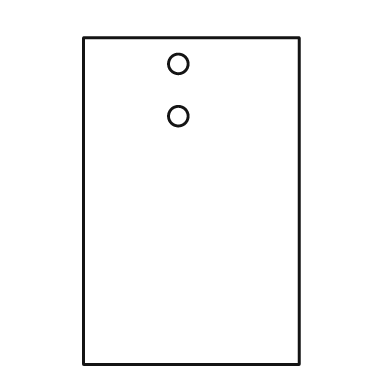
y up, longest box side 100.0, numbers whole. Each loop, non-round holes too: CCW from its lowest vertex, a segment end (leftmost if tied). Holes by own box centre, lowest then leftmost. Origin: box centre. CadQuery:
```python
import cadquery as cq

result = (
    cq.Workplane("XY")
    .moveTo(-33.0, -50.0)
    .lineTo(33.0, -50.0)
    .lineTo(33.0, 50.0)
    .lineTo(-33.0, 50.0)
    .close()
    .moveTo(-4.0, 26.0)
    .circle(3.0)
    .moveTo(-4.0, 42.0)
    .circle(3.0)
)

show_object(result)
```